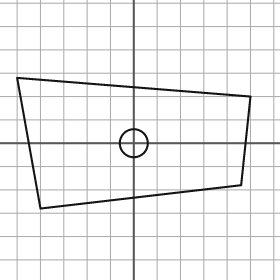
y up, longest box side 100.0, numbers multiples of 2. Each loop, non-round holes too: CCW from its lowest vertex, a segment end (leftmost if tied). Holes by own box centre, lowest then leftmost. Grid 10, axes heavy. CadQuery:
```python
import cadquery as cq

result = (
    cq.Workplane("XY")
    .moveTo(-40.0, -28.0)
    .lineTo(46.0, -18.0)
    .lineTo(50.0, 20.0)
    .lineTo(-50.0, 28.0)
    .close()
    .moveTo(0.0, 0.0)
    .circle(6.0)
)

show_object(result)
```